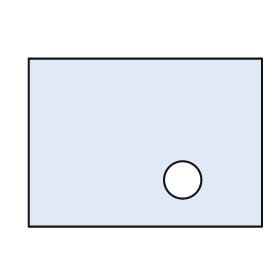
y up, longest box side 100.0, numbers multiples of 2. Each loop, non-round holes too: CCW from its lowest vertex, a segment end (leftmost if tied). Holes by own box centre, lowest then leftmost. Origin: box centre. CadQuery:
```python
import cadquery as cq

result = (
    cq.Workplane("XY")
    .moveTo(-50.0, -36.0)
    .lineTo(50.0, -36.0)
    .lineTo(50.0, 36.0)
    .lineTo(-50.0, 36.0)
    .close()
    .moveTo(16.0, -16.0)
    .circle(8.0)
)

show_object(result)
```